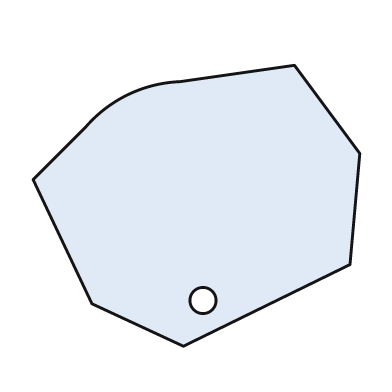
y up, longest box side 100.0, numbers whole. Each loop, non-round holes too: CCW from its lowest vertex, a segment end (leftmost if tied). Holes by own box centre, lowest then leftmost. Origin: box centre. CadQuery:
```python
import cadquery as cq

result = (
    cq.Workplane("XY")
    .moveTo(-4.0, -43.0)
    .lineTo(47.0, -18.0)
    .lineTo(50.0, 16.0)
    .lineTo(30.0, 43.0)
    .lineTo(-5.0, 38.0)
    .threePointArc((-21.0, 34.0), (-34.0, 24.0))
    .lineTo(-50.0, 8.0)
    .lineTo(-32.0, -30.0)
    .close()
    .moveTo(2.0, -29.0)
    .circle(4.0)
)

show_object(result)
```